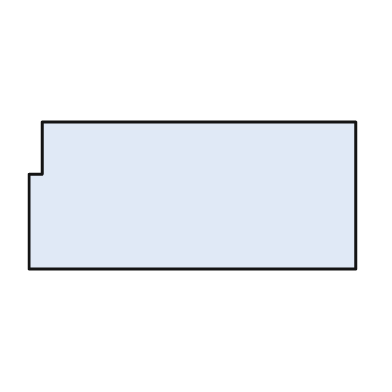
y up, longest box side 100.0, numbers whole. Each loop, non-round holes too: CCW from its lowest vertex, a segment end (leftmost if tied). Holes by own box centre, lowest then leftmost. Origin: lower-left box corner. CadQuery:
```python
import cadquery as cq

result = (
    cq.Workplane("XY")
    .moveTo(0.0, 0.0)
    .lineTo(100.0, 0.0)
    .lineTo(100.0, 45.0)
    .lineTo(4.0, 45.0)
    .lineTo(4.0, 29.0)
    .lineTo(0.0, 29.0)
    .close()
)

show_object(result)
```